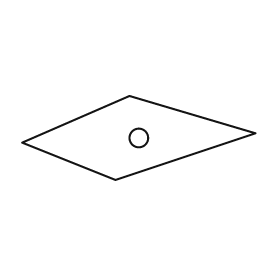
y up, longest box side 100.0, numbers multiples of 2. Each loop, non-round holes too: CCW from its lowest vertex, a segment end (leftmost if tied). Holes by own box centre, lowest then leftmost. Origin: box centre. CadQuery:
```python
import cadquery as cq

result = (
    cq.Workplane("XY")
    .moveTo(-10.0, -18.0)
    .lineTo(50.0, 2.0)
    .lineTo(-4.0, 18.0)
    .lineTo(-50.0, -2.0)
    .close()
    .moveTo(0.0, 0.0)
    .circle(4.0)
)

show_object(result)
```